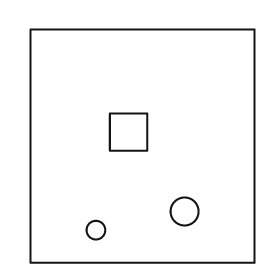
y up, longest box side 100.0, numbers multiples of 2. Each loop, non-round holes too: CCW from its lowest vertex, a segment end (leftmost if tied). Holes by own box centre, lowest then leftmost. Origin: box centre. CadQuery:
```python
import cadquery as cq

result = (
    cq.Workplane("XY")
    .moveTo(-48.0, -50.0)
    .lineTo(48.0, -50.0)
    .lineTo(48.0, 50.0)
    .lineTo(-48.0, 50.0)
    .close()
    .moveTo(-20.0, -36.0)
    .circle(4.0)
    .moveTo(18.0, -28.0)
    .circle(6.0)
    .moveTo(-14.0, -2.0)
    .lineTo(2.0, -2.0)
    .lineTo(2.0, 14.0)
    .lineTo(-14.0, 14.0)
    .close()
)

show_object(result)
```